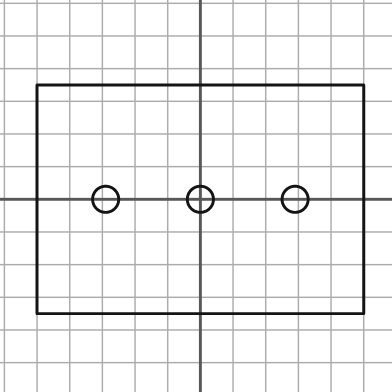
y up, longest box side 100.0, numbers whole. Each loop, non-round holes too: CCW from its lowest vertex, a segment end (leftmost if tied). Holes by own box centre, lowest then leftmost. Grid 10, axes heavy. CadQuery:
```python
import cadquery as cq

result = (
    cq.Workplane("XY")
    .moveTo(-50.0, -35.0)
    .lineTo(50.0, -35.0)
    .lineTo(50.0, 35.0)
    .lineTo(-50.0, 35.0)
    .close()
    .moveTo(-29.0, 0.0)
    .circle(4.0)
    .moveTo(0.0, 0.0)
    .circle(4.0)
    .moveTo(29.0, 0.0)
    .circle(4.0)
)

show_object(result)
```